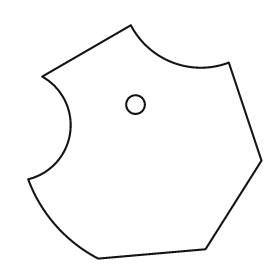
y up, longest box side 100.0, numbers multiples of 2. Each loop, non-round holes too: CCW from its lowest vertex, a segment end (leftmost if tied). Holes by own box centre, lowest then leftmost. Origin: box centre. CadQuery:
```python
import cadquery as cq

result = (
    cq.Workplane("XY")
    .moveTo(-20.0, -50.0)
    .lineTo(26.0, -46.0)
    .lineTo(50.0, -8.0)
    .lineTo(36.0, 34.0)
    .threePointArc((12.0, 34.0), (-6.0, 50.0))
    .lineTo(-44.0, 28.0)
    .threePointArc((-32.0, 4.0), (-50.0, -16.0))
    .threePointArc((-38.0, -36.0), (-20.0, -50.0))
    .close()
    .moveTo(-4.0, 16.0)
    .circle(4.0)
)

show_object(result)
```